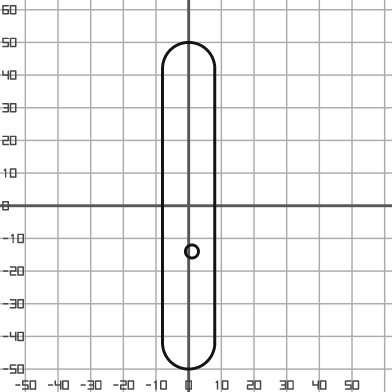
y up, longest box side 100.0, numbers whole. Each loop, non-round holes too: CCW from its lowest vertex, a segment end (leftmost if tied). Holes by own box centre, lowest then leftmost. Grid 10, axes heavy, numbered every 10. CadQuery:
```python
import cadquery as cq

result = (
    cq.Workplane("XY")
    .moveTo(-8.0, -42.0)
    .threePointArc((0.0, -50.0), (8.0, -42.0))
    .lineTo(8.0, 42.0)
    .threePointArc((0.0, 50.0), (-8.0, 42.0))
    .close()
    .moveTo(1.0, -14.0)
    .circle(2.0)
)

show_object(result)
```